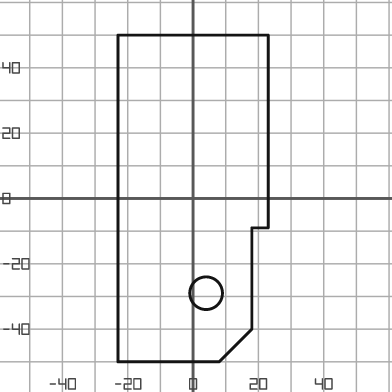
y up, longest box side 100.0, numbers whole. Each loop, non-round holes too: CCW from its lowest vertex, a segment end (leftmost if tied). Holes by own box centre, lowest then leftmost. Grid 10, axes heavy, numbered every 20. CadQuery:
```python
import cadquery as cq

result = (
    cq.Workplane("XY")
    .moveTo(-23.0, -50.0)
    .lineTo(8.0, -50.0)
    .lineTo(18.0, -40.0)
    .lineTo(18.0, -9.0)
    .lineTo(23.0, -9.0)
    .lineTo(23.0, 50.0)
    .lineTo(-23.0, 50.0)
    .close()
    .moveTo(4.0, -29.0)
    .circle(5.0)
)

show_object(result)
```